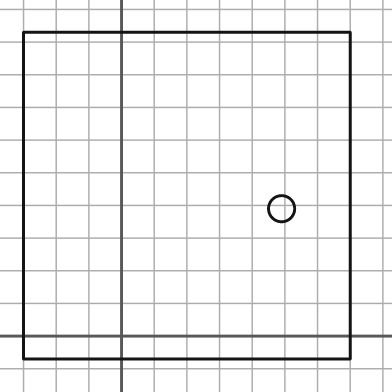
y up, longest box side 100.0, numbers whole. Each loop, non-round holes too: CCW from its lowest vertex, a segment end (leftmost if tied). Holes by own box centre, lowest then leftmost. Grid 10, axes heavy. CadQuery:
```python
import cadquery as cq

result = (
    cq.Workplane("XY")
    .moveTo(-30.0, -7.0)
    .lineTo(70.0, -7.0)
    .lineTo(70.0, 93.0)
    .lineTo(-30.0, 93.0)
    .close()
    .moveTo(49.0, 39.0)
    .circle(4.0)
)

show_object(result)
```